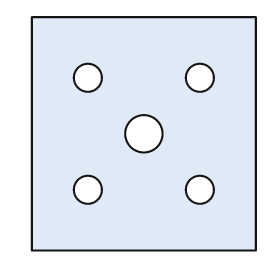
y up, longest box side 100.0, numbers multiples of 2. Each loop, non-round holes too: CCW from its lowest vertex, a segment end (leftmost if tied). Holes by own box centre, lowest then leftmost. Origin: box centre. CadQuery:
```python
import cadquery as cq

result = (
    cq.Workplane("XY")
    .moveTo(-48.0, -50.0)
    .lineTo(48.0, -50.0)
    .lineTo(48.0, 50.0)
    .lineTo(-48.0, 50.0)
    .close()
    .moveTo(-24.0, -24.0)
    .circle(6.0)
    .moveTo(24.0, -24.0)
    .circle(6.0)
    .moveTo(0.0, 0.0)
    .circle(8.0)
    .moveTo(-24.0, 24.0)
    .circle(6.0)
    .moveTo(24.0, 24.0)
    .circle(6.0)
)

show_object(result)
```